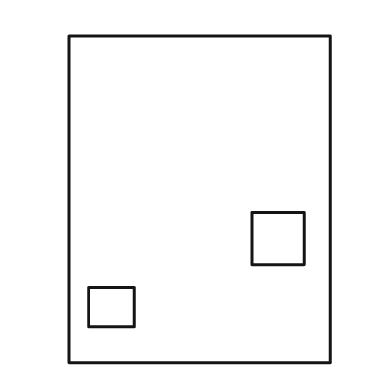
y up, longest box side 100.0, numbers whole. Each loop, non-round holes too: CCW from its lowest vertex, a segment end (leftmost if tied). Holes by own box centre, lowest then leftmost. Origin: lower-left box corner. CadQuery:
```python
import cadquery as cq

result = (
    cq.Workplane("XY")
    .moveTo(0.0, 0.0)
    .lineTo(80.0, 0.0)
    .lineTo(80.0, 100.0)
    .lineTo(0.0, 100.0)
    .close()
    .moveTo(6.0, 11.0)
    .lineTo(20.0, 11.0)
    .lineTo(20.0, 23.0)
    .lineTo(6.0, 23.0)
    .close()
    .moveTo(56.0, 30.0)
    .lineTo(72.0, 30.0)
    .lineTo(72.0, 46.0)
    .lineTo(56.0, 46.0)
    .close()
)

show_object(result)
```